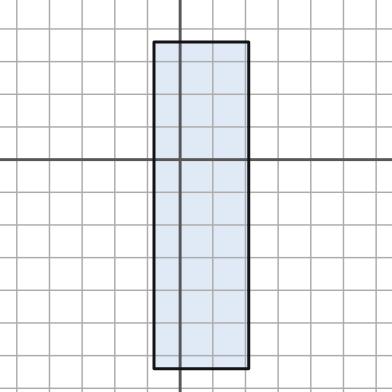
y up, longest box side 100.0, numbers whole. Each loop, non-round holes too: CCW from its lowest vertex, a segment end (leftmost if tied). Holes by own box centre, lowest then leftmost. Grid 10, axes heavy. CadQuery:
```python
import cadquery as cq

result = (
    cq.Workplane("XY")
    .moveTo(-8.0, -64.0)
    .lineTo(21.0, -64.0)
    .lineTo(21.0, 36.0)
    .lineTo(-8.0, 36.0)
    .close()
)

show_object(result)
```